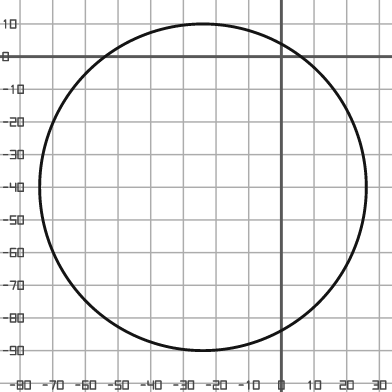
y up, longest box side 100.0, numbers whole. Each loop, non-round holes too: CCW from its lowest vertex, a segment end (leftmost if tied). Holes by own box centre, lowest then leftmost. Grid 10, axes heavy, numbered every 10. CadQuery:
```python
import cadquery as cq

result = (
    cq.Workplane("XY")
    .moveTo(-24.0, -40.0)
    .circle(50.0)
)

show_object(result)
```